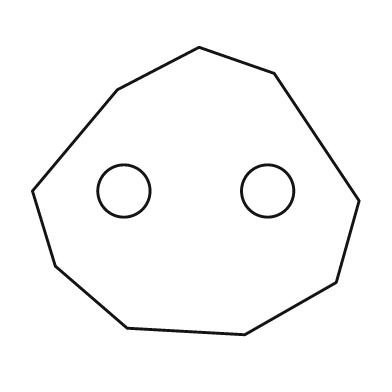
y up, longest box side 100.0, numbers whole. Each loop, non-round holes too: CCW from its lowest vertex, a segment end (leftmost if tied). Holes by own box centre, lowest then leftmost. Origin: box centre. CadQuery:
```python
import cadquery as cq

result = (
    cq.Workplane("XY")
    .moveTo(15.0, -44.0)
    .lineTo(43.0, -28.0)
    .lineTo(50.0, -3.0)
    .lineTo(24.0, 36.0)
    .lineTo(1.0, 44.0)
    .lineTo(-24.0, 31.0)
    .lineTo(-50.0, 0.0)
    .lineTo(-43.0, -23.0)
    .lineTo(-21.0, -42.0)
    .close()
    .moveTo(-22.0, 0.0)
    .circle(8.0)
    .moveTo(22.0, 0.0)
    .circle(8.0)
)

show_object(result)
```